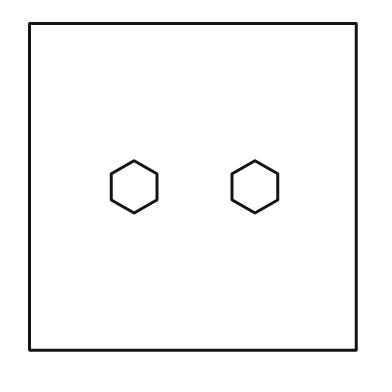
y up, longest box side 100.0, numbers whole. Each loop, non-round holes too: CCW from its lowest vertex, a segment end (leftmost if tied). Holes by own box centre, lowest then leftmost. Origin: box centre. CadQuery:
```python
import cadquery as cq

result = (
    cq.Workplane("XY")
    .moveTo(-50.0, -50.0)
    .lineTo(50.0, -50.0)
    .lineTo(50.0, 50.0)
    .lineTo(-50.0, 50.0)
    .close()
    .moveTo(-18.0, -8.0)
    .lineTo(-11.0, -4.0)
    .lineTo(-11.0, 4.0)
    .lineTo(-18.0, 8.0)
    .lineTo(-25.0, 4.0)
    .lineTo(-25.0, -4.0)
    .close()
    .moveTo(19.0, -8.0)
    .lineTo(26.0, -4.0)
    .lineTo(26.0, 4.0)
    .lineTo(19.0, 8.0)
    .lineTo(12.0, 4.0)
    .lineTo(12.0, -4.0)
    .close()
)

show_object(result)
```